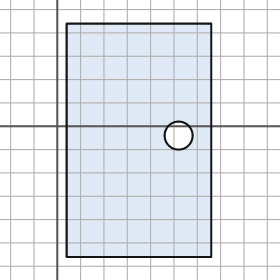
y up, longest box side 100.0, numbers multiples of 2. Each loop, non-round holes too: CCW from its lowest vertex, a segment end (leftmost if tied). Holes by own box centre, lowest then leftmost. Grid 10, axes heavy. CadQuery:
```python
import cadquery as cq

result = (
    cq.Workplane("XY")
    .moveTo(4.0, -56.0)
    .lineTo(66.0, -56.0)
    .lineTo(66.0, 44.0)
    .lineTo(4.0, 44.0)
    .close()
    .moveTo(52.0, -4.0)
    .circle(6.0)
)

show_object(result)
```